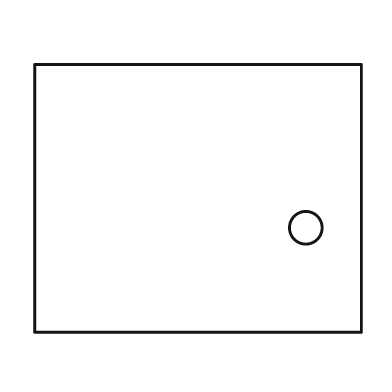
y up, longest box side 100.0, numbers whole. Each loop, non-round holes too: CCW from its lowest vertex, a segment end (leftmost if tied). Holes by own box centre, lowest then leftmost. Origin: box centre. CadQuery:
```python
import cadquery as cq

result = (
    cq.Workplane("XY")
    .moveTo(-50.0, -41.0)
    .lineTo(50.0, -41.0)
    .lineTo(50.0, 41.0)
    .lineTo(-50.0, 41.0)
    .close()
    .moveTo(33.0, -9.0)
    .circle(5.0)
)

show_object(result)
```